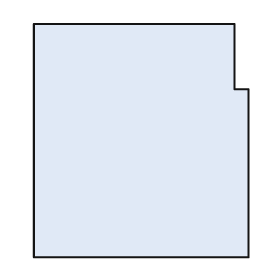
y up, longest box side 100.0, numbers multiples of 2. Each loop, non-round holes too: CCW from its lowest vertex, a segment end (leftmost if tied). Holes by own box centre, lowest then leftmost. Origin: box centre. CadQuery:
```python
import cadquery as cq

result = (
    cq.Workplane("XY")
    .moveTo(-46.0, -50.0)
    .lineTo(46.0, -50.0)
    .lineTo(46.0, 22.0)
    .lineTo(40.0, 22.0)
    .lineTo(40.0, 50.0)
    .lineTo(-46.0, 50.0)
    .close()
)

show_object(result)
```